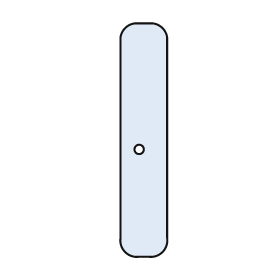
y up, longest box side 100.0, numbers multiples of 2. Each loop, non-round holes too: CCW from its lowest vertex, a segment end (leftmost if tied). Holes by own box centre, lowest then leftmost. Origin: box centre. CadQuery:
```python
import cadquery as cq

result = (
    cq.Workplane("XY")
    .moveTo(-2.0, -50.0)
    .lineTo(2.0, -50.0)
    .threePointArc((8.0, -48.0), (10.0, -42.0))
    .lineTo(10.0, 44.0)
    .threePointArc((8.0, 48.0), (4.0, 50.0))
    .lineTo(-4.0, 50.0)
    .threePointArc((-8.0, 48.0), (-10.0, 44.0))
    .lineTo(-10.0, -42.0)
    .threePointArc((-8.0, -48.0), (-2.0, -50.0))
    .close()
    .moveTo(-2.0, -4.0)
    .circle(2.0)
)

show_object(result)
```